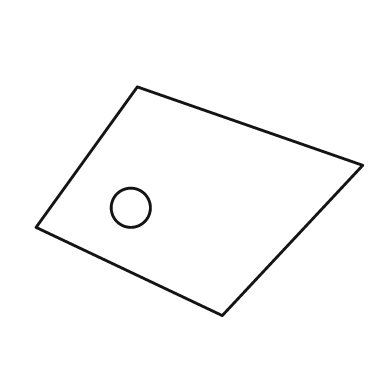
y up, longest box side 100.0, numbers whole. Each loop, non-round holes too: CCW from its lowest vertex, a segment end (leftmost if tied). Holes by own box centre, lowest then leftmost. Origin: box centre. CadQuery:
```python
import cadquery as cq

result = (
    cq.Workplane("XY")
    .moveTo(7.0, -35.0)
    .lineTo(50.0, 11.0)
    .lineTo(-19.0, 35.0)
    .lineTo(-50.0, -8.0)
    .close()
    .moveTo(-21.0, -2.0)
    .circle(6.0)
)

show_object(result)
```